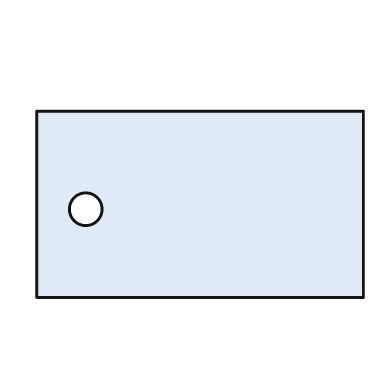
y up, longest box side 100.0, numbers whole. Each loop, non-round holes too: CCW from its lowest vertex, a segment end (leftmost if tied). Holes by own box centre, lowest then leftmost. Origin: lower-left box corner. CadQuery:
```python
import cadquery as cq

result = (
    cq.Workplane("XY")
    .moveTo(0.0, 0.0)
    .lineTo(100.0, 0.0)
    .lineTo(100.0, 57.0)
    .lineTo(0.0, 57.0)
    .close()
    .moveTo(15.0, 27.0)
    .circle(5.0)
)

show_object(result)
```